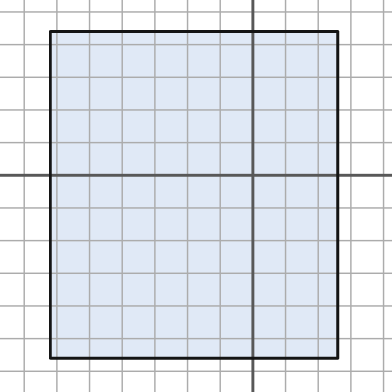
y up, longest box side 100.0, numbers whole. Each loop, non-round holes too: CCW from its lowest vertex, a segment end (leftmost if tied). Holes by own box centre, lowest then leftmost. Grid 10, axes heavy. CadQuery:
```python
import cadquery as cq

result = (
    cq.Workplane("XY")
    .moveTo(-62.0, -56.0)
    .lineTo(26.0, -56.0)
    .lineTo(26.0, 44.0)
    .lineTo(-62.0, 44.0)
    .close()
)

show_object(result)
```